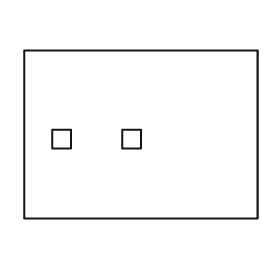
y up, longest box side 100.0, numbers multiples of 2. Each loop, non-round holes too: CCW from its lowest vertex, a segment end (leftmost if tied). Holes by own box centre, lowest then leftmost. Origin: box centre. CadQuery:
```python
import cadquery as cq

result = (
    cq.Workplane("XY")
    .moveTo(-50.0, -36.0)
    .lineTo(50.0, -36.0)
    .lineTo(50.0, 36.0)
    .lineTo(-50.0, 36.0)
    .close()
    .moveTo(-38.0, -6.0)
    .lineTo(-30.0, -6.0)
    .lineTo(-30.0, 2.0)
    .lineTo(-38.0, 2.0)
    .close()
    .moveTo(-8.0, -6.0)
    .lineTo(0.0, -6.0)
    .lineTo(0.0, 2.0)
    .lineTo(-8.0, 2.0)
    .close()
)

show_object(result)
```